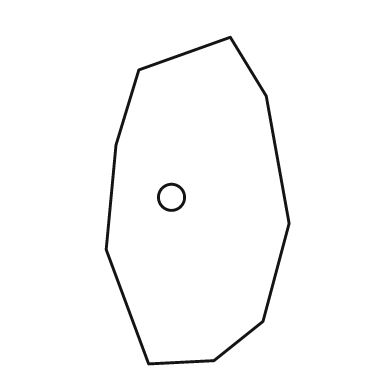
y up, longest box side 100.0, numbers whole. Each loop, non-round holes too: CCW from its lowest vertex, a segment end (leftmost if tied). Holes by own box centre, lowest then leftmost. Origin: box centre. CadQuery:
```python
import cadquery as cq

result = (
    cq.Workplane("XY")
    .moveTo(-15.0, -50.0)
    .lineTo(5.0, -49.0)
    .lineTo(20.0, -37.0)
    .lineTo(28.0, -7.0)
    .lineTo(21.0, 32.0)
    .lineTo(10.0, 50.0)
    .lineTo(-18.0, 40.0)
    .lineTo(-25.0, 17.0)
    .lineTo(-28.0, -15.0)
    .close()
    .moveTo(-8.0, 1.0)
    .circle(4.0)
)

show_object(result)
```